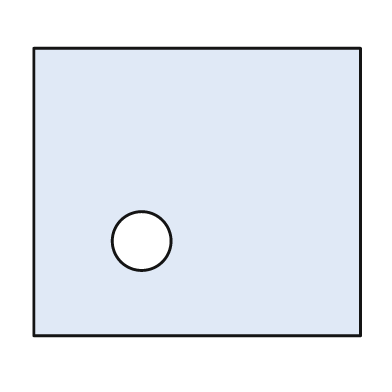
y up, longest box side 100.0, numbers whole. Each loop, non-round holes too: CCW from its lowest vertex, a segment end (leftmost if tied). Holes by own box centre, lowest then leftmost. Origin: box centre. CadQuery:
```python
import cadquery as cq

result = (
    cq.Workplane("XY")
    .moveTo(-50.0, -44.0)
    .lineTo(50.0, -44.0)
    .lineTo(50.0, 44.0)
    .lineTo(-50.0, 44.0)
    .close()
    .moveTo(-17.0, -15.0)
    .circle(9.0)
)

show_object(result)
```